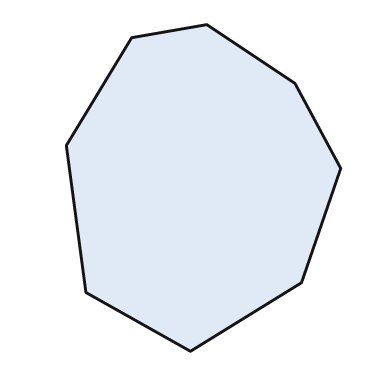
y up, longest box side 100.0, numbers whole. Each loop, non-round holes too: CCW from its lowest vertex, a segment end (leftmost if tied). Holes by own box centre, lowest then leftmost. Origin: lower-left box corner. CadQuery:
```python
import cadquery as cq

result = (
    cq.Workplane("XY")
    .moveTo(38.0, 0.0)
    .lineTo(72.0, 21.0)
    .lineTo(84.0, 56.0)
    .lineTo(70.0, 82.0)
    .lineTo(43.0, 100.0)
    .lineTo(20.0, 96.0)
    .lineTo(0.0, 63.0)
    .lineTo(6.0, 18.0)
    .close()
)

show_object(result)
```